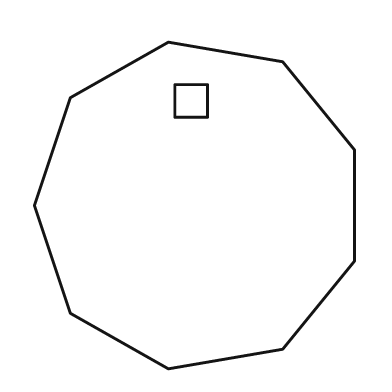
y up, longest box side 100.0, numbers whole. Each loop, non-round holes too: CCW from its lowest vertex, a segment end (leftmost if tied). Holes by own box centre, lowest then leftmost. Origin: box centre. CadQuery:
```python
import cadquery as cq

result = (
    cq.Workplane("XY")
    .moveTo(-8.0, -50.0)
    .lineTo(27.0, -44.0)
    .lineTo(49.0, -17.0)
    .lineTo(49.0, 17.0)
    .lineTo(27.0, 44.0)
    .lineTo(-8.0, 50.0)
    .lineTo(-38.0, 33.0)
    .lineTo(-49.0, 0.0)
    .lineTo(-38.0, -33.0)
    .close()
    .moveTo(-6.0, 27.0)
    .lineTo(4.0, 27.0)
    .lineTo(4.0, 37.0)
    .lineTo(-6.0, 37.0)
    .close()
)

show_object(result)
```